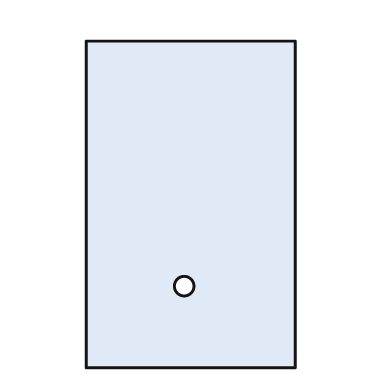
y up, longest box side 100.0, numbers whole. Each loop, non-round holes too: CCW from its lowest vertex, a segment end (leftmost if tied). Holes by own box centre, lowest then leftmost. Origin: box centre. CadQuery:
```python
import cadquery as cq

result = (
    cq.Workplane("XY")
    .moveTo(-32.0, -50.0)
    .lineTo(32.0, -50.0)
    .lineTo(32.0, 50.0)
    .lineTo(-32.0, 50.0)
    .close()
    .moveTo(-2.0, -25.0)
    .circle(3.0)
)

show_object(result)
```